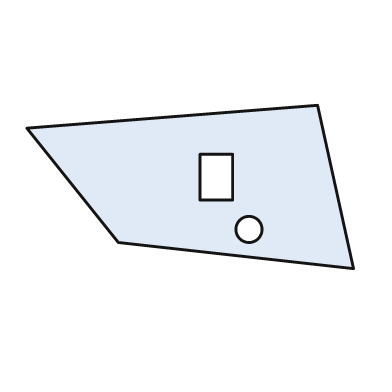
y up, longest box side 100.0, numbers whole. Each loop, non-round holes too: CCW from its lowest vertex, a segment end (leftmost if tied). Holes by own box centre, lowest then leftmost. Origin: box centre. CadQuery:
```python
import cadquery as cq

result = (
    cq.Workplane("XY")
    .moveTo(50.0, -25.0)
    .lineTo(39.0, 25.0)
    .lineTo(-50.0, 18.0)
    .lineTo(-22.0, -17.0)
    .close()
    .moveTo(18.0, -13.0)
    .circle(4.0)
    .moveTo(3.0, -4.0)
    .lineTo(13.0, -4.0)
    .lineTo(13.0, 10.0)
    .lineTo(3.0, 10.0)
    .close()
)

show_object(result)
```